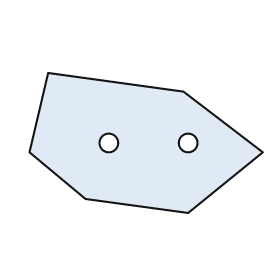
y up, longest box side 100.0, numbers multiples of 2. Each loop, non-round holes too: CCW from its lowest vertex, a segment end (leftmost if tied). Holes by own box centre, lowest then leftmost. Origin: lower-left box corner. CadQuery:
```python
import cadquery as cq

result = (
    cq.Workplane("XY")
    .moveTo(68.0, 0.0)
    .lineTo(100.0, 26.0)
    .lineTo(66.0, 52.0)
    .lineTo(8.0, 60.0)
    .lineTo(0.0, 26.0)
    .lineTo(24.0, 6.0)
    .close()
    .moveTo(34.0, 30.0)
    .circle(4.0)
    .moveTo(68.0, 30.0)
    .circle(4.0)
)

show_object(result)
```